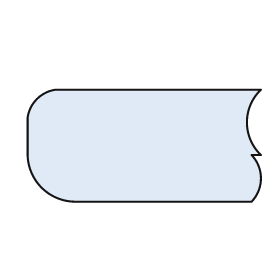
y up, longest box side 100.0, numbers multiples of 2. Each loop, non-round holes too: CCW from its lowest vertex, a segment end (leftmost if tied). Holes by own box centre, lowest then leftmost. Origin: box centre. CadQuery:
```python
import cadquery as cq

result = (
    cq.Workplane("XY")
    .moveTo(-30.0, -24.0)
    .lineTo(46.0, -24.0)
    .threePointArc((50.0, -14.0), (46.0, -4.0))
    .lineTo(50.0, -4.0)
    .threePointArc((44.0, 10.0), (50.0, 24.0))
    .lineTo(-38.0, 24.0)
    .threePointArc((-46.0, 20.0), (-50.0, 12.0))
    .lineTo(-50.0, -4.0)
    .threePointArc((-44.0, -18.0), (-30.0, -24.0))
    .close()
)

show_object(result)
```